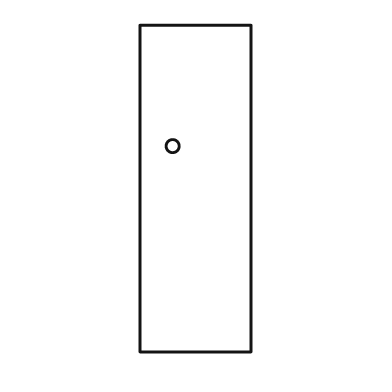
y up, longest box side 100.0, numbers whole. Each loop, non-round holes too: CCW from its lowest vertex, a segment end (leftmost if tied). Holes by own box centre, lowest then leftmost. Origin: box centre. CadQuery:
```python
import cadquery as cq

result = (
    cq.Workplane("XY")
    .moveTo(-17.0, -50.0)
    .lineTo(17.0, -50.0)
    .lineTo(17.0, 50.0)
    .lineTo(-17.0, 50.0)
    .close()
    .moveTo(-7.0, 13.0)
    .circle(2.0)
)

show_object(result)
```